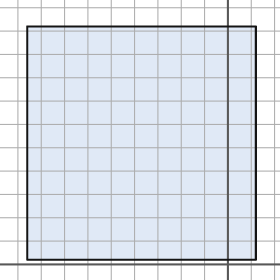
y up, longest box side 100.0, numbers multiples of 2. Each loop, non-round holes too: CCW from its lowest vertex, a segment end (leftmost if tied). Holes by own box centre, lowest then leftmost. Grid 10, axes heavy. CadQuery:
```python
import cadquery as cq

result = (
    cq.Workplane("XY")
    .moveTo(-86.0, 2.0)
    .lineTo(12.0, 2.0)
    .lineTo(12.0, 102.0)
    .lineTo(-86.0, 102.0)
    .close()
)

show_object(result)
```